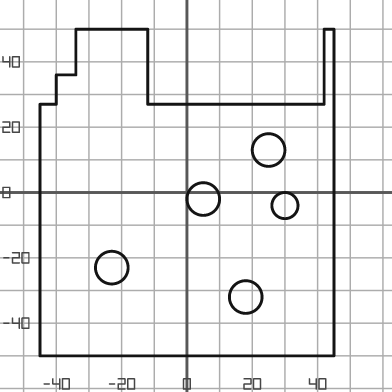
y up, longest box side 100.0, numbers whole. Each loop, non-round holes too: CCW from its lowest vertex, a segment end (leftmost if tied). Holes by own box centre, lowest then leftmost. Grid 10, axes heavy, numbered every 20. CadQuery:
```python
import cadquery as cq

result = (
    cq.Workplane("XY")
    .moveTo(-45.0, -50.0)
    .lineTo(45.0, -50.0)
    .lineTo(45.0, 50.0)
    .lineTo(42.0, 50.0)
    .lineTo(42.0, 27.0)
    .lineTo(-12.0, 27.0)
    .lineTo(-12.0, 50.0)
    .lineTo(-34.0, 50.0)
    .lineTo(-34.0, 36.0)
    .lineTo(-40.0, 36.0)
    .lineTo(-40.0, 27.0)
    .lineTo(-45.0, 27.0)
    .close()
    .moveTo(18.0, -32.0)
    .circle(5.0)
    .moveTo(-23.0, -23.0)
    .circle(5.0)
    .moveTo(30.0, -4.0)
    .circle(4.0)
    .moveTo(5.0, -2.0)
    .circle(5.0)
    .moveTo(25.0, 13.0)
    .circle(5.0)
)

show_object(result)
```